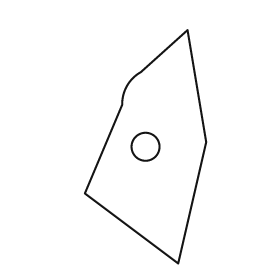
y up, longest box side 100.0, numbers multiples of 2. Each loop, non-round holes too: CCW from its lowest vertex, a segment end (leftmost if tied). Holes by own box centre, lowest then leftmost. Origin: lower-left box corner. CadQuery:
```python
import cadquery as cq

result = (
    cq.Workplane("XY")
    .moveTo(40.0, 0.0)
    .lineTo(52.0, 52.0)
    .lineTo(44.0, 100.0)
    .lineTo(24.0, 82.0)
    .threePointArc((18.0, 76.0), (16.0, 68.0))
    .lineTo(0.0, 30.0)
    .close()
    .moveTo(26.0, 50.0)
    .circle(6.0)
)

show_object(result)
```